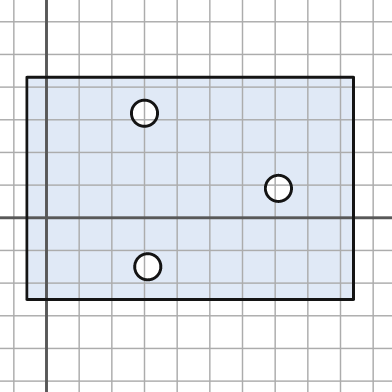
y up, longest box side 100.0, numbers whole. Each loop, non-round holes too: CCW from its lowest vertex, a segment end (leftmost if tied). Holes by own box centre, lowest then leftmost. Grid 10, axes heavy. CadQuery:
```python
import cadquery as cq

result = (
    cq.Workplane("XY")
    .moveTo(-6.0, -25.0)
    .lineTo(94.0, -25.0)
    .lineTo(94.0, 43.0)
    .lineTo(-6.0, 43.0)
    .close()
    .moveTo(31.0, -15.0)
    .circle(4.0)
    .moveTo(71.0, 9.0)
    .circle(4.0)
    .moveTo(30.0, 32.0)
    .circle(4.0)
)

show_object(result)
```